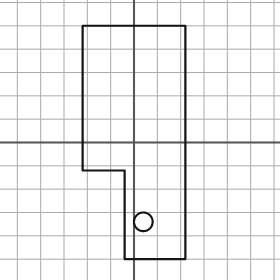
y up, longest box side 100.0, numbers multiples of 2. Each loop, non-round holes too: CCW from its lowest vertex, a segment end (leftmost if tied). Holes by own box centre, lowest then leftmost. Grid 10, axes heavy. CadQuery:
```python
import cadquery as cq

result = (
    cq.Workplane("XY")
    .moveTo(-4.0, -50.0)
    .lineTo(22.0, -50.0)
    .lineTo(22.0, 50.0)
    .lineTo(-22.0, 50.0)
    .lineTo(-22.0, -12.0)
    .lineTo(-4.0, -12.0)
    .close()
    .moveTo(4.0, -34.0)
    .circle(4.0)
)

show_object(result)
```